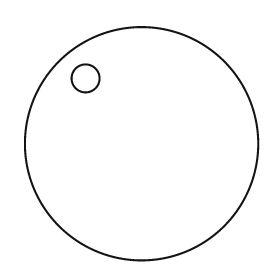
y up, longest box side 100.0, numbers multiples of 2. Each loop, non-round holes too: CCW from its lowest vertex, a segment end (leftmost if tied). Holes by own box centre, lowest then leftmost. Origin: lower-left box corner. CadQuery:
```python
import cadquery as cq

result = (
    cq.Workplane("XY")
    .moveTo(50.0, 50.0)
    .circle(50.0)
    .moveTo(26.0, 78.0)
    .circle(6.0)
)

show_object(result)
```